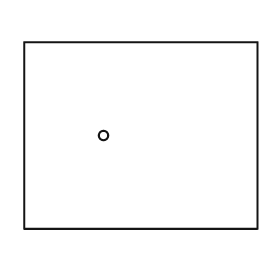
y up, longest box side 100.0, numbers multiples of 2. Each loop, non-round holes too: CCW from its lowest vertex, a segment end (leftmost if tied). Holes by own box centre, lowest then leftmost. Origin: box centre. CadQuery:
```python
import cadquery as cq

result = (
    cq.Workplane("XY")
    .moveTo(-50.0, -40.0)
    .lineTo(50.0, -40.0)
    .lineTo(50.0, 40.0)
    .lineTo(-50.0, 40.0)
    .close()
    .moveTo(-16.0, 0.0)
    .circle(2.0)
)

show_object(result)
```